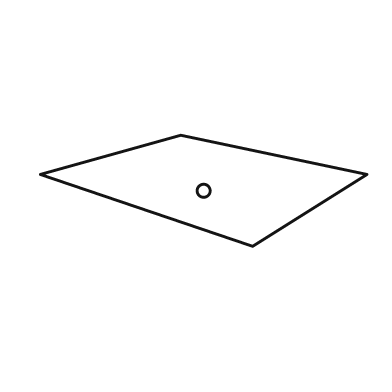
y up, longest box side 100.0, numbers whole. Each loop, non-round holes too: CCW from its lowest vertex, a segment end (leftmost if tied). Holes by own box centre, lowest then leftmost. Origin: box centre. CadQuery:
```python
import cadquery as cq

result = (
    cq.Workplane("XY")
    .moveTo(15.0, -17.0)
    .lineTo(50.0, 5.0)
    .lineTo(-7.0, 17.0)
    .lineTo(-50.0, 5.0)
    .close()
    .moveTo(0.0, 0.0)
    .circle(2.0)
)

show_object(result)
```